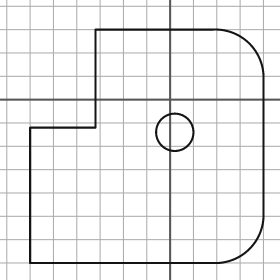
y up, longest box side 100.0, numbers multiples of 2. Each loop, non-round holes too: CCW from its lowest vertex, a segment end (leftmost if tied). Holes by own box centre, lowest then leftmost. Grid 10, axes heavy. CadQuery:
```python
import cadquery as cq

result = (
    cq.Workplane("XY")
    .moveTo(-60.0, -70.0)
    .lineTo(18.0, -70.0)
    .threePointArc((34.0, -64.0), (40.0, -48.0))
    .lineTo(40.0, 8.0)
    .threePointArc((34.0, 24.0), (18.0, 30.0))
    .lineTo(-32.0, 30.0)
    .lineTo(-32.0, -12.0)
    .lineTo(-60.0, -12.0)
    .close()
    .moveTo(2.0, -14.0)
    .circle(8.0)
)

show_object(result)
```